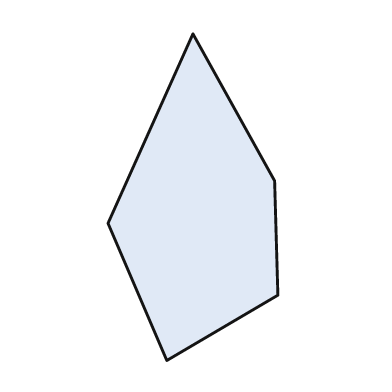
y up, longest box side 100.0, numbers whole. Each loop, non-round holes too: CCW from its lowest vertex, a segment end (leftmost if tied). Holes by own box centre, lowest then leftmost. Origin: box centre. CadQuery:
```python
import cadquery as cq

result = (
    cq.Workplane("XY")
    .moveTo(-8.0, -50.0)
    .lineTo(26.0, -30.0)
    .lineTo(25.0, 5.0)
    .lineTo(0.0, 50.0)
    .lineTo(-26.0, -8.0)
    .close()
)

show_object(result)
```